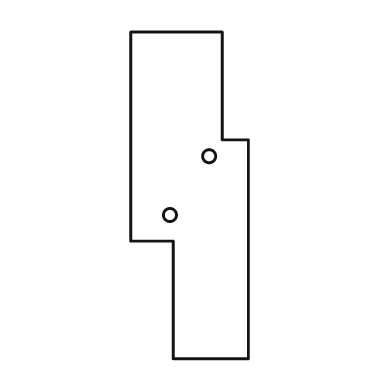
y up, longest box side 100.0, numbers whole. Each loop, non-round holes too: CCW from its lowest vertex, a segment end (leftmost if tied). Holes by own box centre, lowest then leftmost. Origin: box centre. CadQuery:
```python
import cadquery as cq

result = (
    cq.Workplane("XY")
    .moveTo(-5.0, -50.0)
    .lineTo(18.0, -50.0)
    .lineTo(18.0, 17.0)
    .lineTo(10.0, 17.0)
    .lineTo(10.0, 50.0)
    .lineTo(-18.0, 50.0)
    .lineTo(-18.0, -14.0)
    .lineTo(-5.0, -14.0)
    .close()
    .moveTo(-6.0, -6.0)
    .circle(2.0)
    .moveTo(6.0, 12.0)
    .circle(2.0)
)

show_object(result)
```